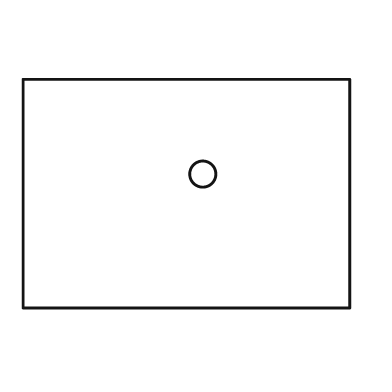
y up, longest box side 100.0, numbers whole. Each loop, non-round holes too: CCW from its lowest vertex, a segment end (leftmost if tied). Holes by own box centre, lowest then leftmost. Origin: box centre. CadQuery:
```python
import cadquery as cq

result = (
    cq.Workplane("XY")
    .moveTo(-50.0, -35.0)
    .lineTo(50.0, -35.0)
    .lineTo(50.0, 35.0)
    .lineTo(-50.0, 35.0)
    .close()
    .moveTo(5.0, 6.0)
    .circle(4.0)
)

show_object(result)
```